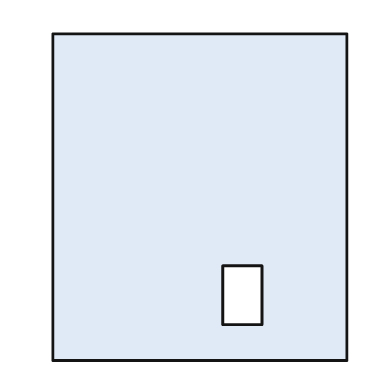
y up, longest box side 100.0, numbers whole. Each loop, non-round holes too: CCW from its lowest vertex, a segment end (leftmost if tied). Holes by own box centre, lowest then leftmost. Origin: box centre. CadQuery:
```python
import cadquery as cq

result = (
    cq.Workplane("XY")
    .moveTo(-45.0, -50.0)
    .lineTo(45.0, -50.0)
    .lineTo(45.0, 50.0)
    .lineTo(-45.0, 50.0)
    .close()
    .moveTo(7.0, -39.0)
    .lineTo(19.0, -39.0)
    .lineTo(19.0, -21.0)
    .lineTo(7.0, -21.0)
    .close()
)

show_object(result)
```